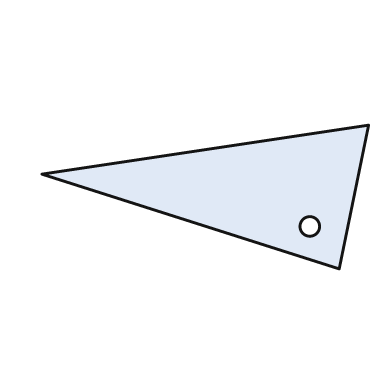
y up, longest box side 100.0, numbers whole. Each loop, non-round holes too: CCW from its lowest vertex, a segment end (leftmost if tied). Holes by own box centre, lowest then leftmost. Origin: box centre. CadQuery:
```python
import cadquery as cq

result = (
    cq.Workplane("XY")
    .moveTo(41.0, -22.0)
    .lineTo(50.0, 22.0)
    .lineTo(-50.0, 7.0)
    .close()
    .moveTo(32.0, -9.0)
    .circle(3.0)
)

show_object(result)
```